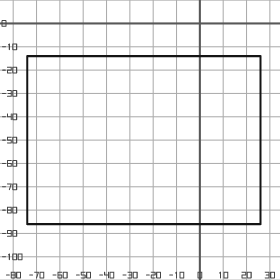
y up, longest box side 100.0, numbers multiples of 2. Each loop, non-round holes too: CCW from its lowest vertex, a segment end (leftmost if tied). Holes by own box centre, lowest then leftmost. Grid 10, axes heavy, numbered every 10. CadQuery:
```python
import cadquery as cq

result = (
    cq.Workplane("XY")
    .moveTo(-74.0, -86.0)
    .lineTo(26.0, -86.0)
    .lineTo(26.0, -14.0)
    .lineTo(-74.0, -14.0)
    .close()
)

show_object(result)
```